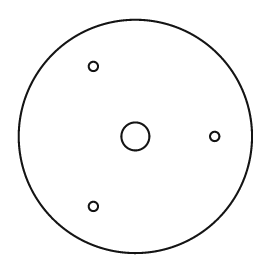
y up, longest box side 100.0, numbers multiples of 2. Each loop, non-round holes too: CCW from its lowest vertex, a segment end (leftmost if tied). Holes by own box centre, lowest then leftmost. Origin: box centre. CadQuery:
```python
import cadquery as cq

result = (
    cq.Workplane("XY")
    .moveTo(0.0, 0.0)
    .circle(50.0)
    .moveTo(-18.0, -30.0)
    .circle(2.0)
    .moveTo(0.0, 0.0)
    .circle(6.0)
    .moveTo(34.0, 0.0)
    .circle(2.0)
    .moveTo(-18.0, 30.0)
    .circle(2.0)
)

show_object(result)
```